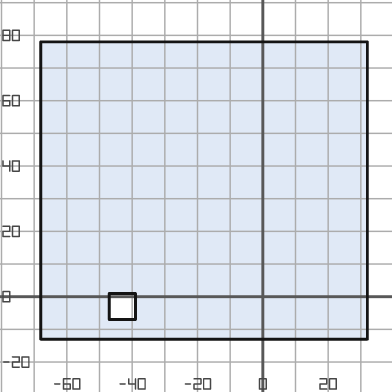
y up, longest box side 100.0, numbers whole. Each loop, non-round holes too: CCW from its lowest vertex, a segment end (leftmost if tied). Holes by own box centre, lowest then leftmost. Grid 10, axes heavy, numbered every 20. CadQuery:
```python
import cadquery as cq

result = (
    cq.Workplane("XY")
    .moveTo(-68.0, -13.0)
    .lineTo(32.0, -13.0)
    .lineTo(32.0, 78.0)
    .lineTo(-68.0, 78.0)
    .close()
    .moveTo(-47.0, -7.0)
    .lineTo(-39.0, -7.0)
    .lineTo(-39.0, 1.0)
    .lineTo(-47.0, 1.0)
    .close()
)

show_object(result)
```